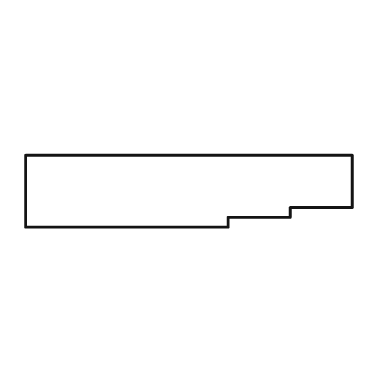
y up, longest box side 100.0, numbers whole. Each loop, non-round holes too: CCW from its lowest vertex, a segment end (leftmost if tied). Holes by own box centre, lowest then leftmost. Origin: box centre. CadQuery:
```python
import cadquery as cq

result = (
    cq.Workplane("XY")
    .moveTo(-50.0, -11.0)
    .lineTo(12.0, -11.0)
    .lineTo(12.0, -8.0)
    .lineTo(31.0, -8.0)
    .lineTo(31.0, -5.0)
    .lineTo(50.0, -5.0)
    .lineTo(50.0, 11.0)
    .lineTo(-50.0, 11.0)
    .close()
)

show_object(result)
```